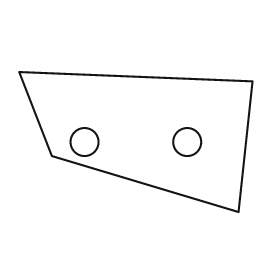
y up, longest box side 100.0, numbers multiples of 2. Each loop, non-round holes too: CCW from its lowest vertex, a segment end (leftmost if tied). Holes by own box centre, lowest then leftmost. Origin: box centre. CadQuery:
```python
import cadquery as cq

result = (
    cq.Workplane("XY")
    .moveTo(44.0, -30.0)
    .lineTo(50.0, 26.0)
    .lineTo(-50.0, 30.0)
    .lineTo(-36.0, -6.0)
    .close()
    .moveTo(-22.0, 0.0)
    .circle(6.0)
    .moveTo(22.0, 0.0)
    .circle(6.0)
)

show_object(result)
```